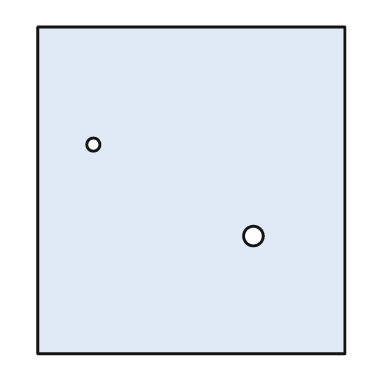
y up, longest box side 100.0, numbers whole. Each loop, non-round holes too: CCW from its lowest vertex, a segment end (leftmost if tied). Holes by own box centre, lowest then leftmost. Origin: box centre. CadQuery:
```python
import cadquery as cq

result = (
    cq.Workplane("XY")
    .moveTo(-47.0, -50.0)
    .lineTo(47.0, -50.0)
    .lineTo(47.0, 50.0)
    .lineTo(-47.0, 50.0)
    .close()
    .moveTo(19.0, -14.0)
    .circle(3.0)
    .moveTo(-30.0, 14.0)
    .circle(2.0)
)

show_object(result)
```